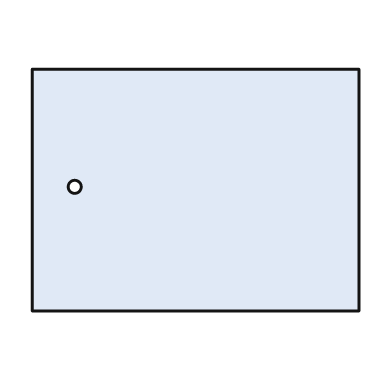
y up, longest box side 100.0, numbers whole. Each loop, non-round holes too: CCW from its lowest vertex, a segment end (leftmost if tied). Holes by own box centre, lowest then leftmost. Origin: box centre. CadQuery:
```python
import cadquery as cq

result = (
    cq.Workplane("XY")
    .moveTo(-50.0, -37.0)
    .lineTo(50.0, -37.0)
    .lineTo(50.0, 37.0)
    .lineTo(-50.0, 37.0)
    .close()
    .moveTo(-37.0, 1.0)
    .circle(2.0)
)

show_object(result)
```